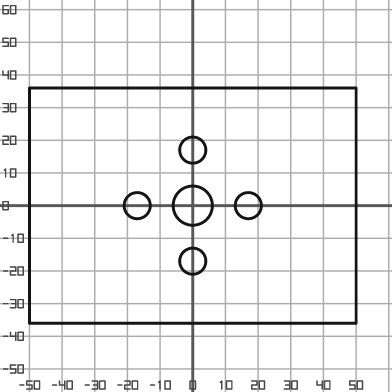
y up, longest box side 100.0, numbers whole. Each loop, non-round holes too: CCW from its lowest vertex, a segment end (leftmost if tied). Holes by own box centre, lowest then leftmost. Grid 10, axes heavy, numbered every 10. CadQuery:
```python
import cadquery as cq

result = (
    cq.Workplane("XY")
    .moveTo(-50.0, -36.0)
    .lineTo(50.0, -36.0)
    .lineTo(50.0, 36.0)
    .lineTo(-50.0, 36.0)
    .close()
    .moveTo(0.0, -17.0)
    .circle(4.0)
    .moveTo(-17.0, 0.0)
    .circle(4.0)
    .moveTo(0.0, 0.0)
    .circle(6.0)
    .moveTo(17.0, 0.0)
    .circle(4.0)
    .moveTo(0.0, 17.0)
    .circle(4.0)
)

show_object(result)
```